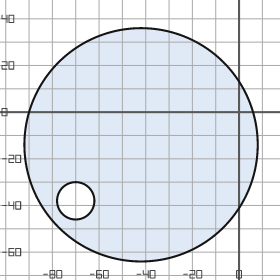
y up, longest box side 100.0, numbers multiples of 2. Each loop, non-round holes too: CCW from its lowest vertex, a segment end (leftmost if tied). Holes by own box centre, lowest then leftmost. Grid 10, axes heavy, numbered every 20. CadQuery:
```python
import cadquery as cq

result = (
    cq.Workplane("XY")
    .moveTo(-42.0, -14.0)
    .circle(50.0)
    .moveTo(-70.0, -38.0)
    .circle(8.0)
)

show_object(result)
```